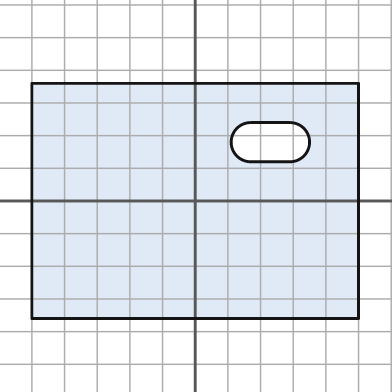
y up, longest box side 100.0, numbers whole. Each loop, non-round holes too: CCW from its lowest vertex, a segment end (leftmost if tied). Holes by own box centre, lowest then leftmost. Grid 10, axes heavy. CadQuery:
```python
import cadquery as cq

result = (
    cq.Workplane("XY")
    .moveTo(-50.0, -36.0)
    .lineTo(50.0, -36.0)
    .lineTo(50.0, 36.0)
    .lineTo(-50.0, 36.0)
    .close()
    .moveTo(17.0, 12.0)
    .lineTo(29.0, 12.0)
    .threePointArc((35.0, 18.0), (29.0, 24.0))
    .lineTo(17.0, 24.0)
    .threePointArc((11.0, 18.0), (17.0, 12.0))
    .close()
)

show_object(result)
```